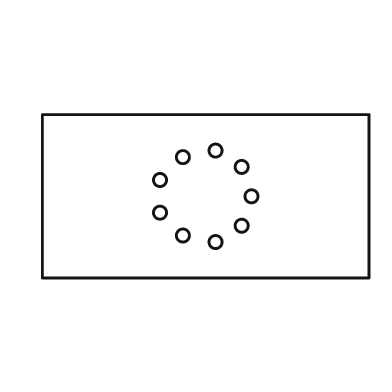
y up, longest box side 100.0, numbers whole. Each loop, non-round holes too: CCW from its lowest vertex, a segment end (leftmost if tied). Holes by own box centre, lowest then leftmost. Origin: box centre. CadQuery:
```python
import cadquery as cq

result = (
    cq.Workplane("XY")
    .moveTo(-50.0, -25.0)
    .lineTo(50.0, -25.0)
    .lineTo(50.0, 25.0)
    .lineTo(-50.0, 25.0)
    .close()
    .moveTo(3.0, -14.0)
    .circle(2.0)
    .moveTo(-7.0, -12.0)
    .circle(2.0)
    .moveTo(11.0, -9.0)
    .circle(2.0)
    .moveTo(-14.0, -5.0)
    .circle(2.0)
    .moveTo(14.0, 0.0)
    .circle(2.0)
    .moveTo(-14.0, 5.0)
    .circle(2.0)
    .moveTo(11.0, 9.0)
    .circle(2.0)
    .moveTo(-7.0, 12.0)
    .circle(2.0)
    .moveTo(3.0, 14.0)
    .circle(2.0)
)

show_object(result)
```